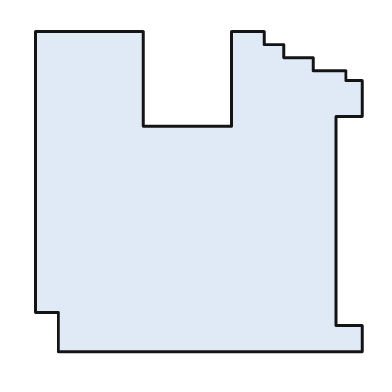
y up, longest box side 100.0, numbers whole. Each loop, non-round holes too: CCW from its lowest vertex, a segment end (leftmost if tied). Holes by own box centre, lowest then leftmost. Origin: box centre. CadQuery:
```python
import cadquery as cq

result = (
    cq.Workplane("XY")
    .moveTo(-43.0, -49.0)
    .lineTo(50.0, -49.0)
    .lineTo(50.0, -41.0)
    .lineTo(42.0, -41.0)
    .lineTo(42.0, 23.0)
    .lineTo(50.0, 23.0)
    .lineTo(50.0, 34.0)
    .lineTo(45.0, 34.0)
    .lineTo(45.0, 37.0)
    .lineTo(35.0, 37.0)
    .lineTo(35.0, 41.0)
    .lineTo(26.0, 41.0)
    .lineTo(26.0, 45.0)
    .lineTo(20.0, 45.0)
    .lineTo(20.0, 49.0)
    .lineTo(10.0, 49.0)
    .lineTo(10.0, 20.0)
    .lineTo(-17.0, 20.0)
    .lineTo(-17.0, 49.0)
    .lineTo(-50.0, 49.0)
    .lineTo(-50.0, -37.0)
    .lineTo(-43.0, -37.0)
    .close()
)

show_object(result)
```